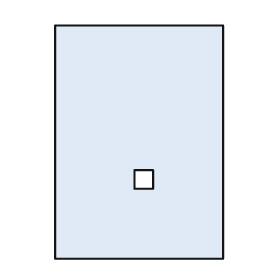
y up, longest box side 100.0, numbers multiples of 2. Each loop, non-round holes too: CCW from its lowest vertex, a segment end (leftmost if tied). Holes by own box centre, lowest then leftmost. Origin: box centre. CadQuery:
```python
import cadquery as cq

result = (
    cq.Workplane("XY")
    .moveTo(-36.0, -50.0)
    .lineTo(36.0, -50.0)
    .lineTo(36.0, 50.0)
    .lineTo(-36.0, 50.0)
    .close()
    .moveTo(-2.0, -20.0)
    .lineTo(6.0, -20.0)
    .lineTo(6.0, -12.0)
    .lineTo(-2.0, -12.0)
    .close()
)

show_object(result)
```